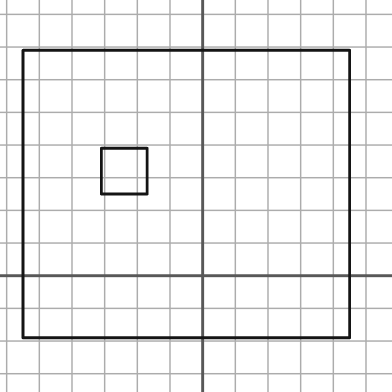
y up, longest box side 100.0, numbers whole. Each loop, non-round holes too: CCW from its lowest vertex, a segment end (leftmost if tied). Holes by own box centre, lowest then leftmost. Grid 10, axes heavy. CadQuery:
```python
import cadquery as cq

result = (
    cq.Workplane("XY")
    .moveTo(-55.0, -19.0)
    .lineTo(45.0, -19.0)
    .lineTo(45.0, 69.0)
    .lineTo(-55.0, 69.0)
    .close()
    .moveTo(-31.0, 25.0)
    .lineTo(-17.0, 25.0)
    .lineTo(-17.0, 39.0)
    .lineTo(-31.0, 39.0)
    .close()
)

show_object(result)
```